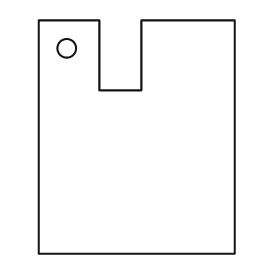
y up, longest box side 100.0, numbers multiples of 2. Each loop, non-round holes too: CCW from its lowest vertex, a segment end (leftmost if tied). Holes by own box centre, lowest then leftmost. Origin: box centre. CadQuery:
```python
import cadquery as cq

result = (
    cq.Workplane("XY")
    .moveTo(-42.0, -50.0)
    .lineTo(42.0, -50.0)
    .lineTo(42.0, 50.0)
    .lineTo(2.0, 50.0)
    .lineTo(2.0, 20.0)
    .lineTo(-16.0, 20.0)
    .lineTo(-16.0, 50.0)
    .lineTo(-42.0, 50.0)
    .close()
    .moveTo(-30.0, 38.0)
    .circle(4.0)
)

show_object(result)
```